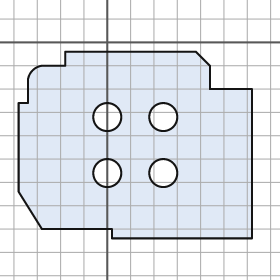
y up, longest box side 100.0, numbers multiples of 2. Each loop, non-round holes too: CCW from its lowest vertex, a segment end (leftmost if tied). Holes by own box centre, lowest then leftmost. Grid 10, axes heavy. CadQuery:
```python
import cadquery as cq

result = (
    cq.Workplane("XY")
    .moveTo(2.0, -84.0)
    .lineTo(62.0, -84.0)
    .lineTo(62.0, -20.0)
    .lineTo(44.0, -20.0)
    .lineTo(44.0, -10.0)
    .lineTo(38.0, -4.0)
    .lineTo(-18.0, -4.0)
    .lineTo(-18.0, -10.0)
    .lineTo(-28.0, -10.0)
    .threePointArc((-32.0, -12.0), (-34.0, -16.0))
    .lineTo(-34.0, -26.0)
    .lineTo(-38.0, -26.0)
    .lineTo(-38.0, -64.0)
    .lineTo(-28.0, -80.0)
    .lineTo(2.0, -80.0)
    .close()
    .moveTo(0.0, -56.0)
    .circle(6.0)
    .moveTo(24.0, -56.0)
    .circle(6.0)
    .moveTo(0.0, -32.0)
    .circle(6.0)
    .moveTo(24.0, -32.0)
    .circle(6.0)
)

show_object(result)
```